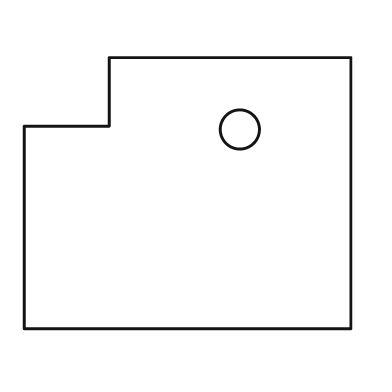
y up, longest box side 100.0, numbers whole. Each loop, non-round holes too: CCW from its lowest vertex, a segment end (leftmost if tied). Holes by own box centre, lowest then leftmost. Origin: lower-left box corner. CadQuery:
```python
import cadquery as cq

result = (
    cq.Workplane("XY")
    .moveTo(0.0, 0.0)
    .lineTo(100.0, 0.0)
    .lineTo(100.0, 83.0)
    .lineTo(26.0, 83.0)
    .lineTo(26.0, 62.0)
    .lineTo(0.0, 62.0)
    .close()
    .moveTo(66.0, 61.0)
    .circle(6.0)
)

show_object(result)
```